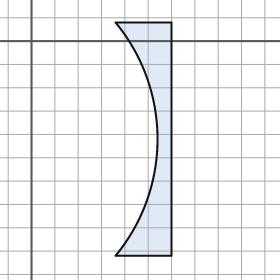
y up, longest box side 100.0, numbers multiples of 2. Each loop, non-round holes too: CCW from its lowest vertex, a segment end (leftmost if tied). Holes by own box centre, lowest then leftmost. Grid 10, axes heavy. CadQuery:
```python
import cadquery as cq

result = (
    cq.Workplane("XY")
    .moveTo(36.0, -92.0)
    .lineTo(60.0, -92.0)
    .lineTo(60.0, 8.0)
    .lineTo(36.0, 8.0)
    .threePointArc((54.0, -42.0), (36.0, -92.0))
    .close()
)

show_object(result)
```